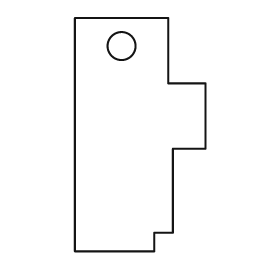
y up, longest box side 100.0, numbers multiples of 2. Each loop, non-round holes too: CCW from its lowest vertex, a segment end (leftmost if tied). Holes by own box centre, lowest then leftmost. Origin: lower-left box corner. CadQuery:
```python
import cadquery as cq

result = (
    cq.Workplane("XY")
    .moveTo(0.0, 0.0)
    .lineTo(34.0, 0.0)
    .lineTo(34.0, 8.0)
    .lineTo(42.0, 8.0)
    .lineTo(42.0, 44.0)
    .lineTo(56.0, 44.0)
    .lineTo(56.0, 72.0)
    .lineTo(40.0, 72.0)
    .lineTo(40.0, 100.0)
    .lineTo(0.0, 100.0)
    .close()
    .moveTo(20.0, 88.0)
    .circle(6.0)
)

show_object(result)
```